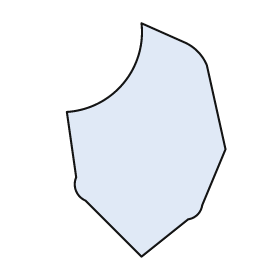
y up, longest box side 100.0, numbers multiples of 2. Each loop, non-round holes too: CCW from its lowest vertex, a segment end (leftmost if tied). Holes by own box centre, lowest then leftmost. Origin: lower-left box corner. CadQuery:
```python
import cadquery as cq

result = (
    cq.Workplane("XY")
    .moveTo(32.0, 0.0)
    .lineTo(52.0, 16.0)
    .threePointArc((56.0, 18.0), (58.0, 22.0))
    .lineTo(68.0, 46.0)
    .lineTo(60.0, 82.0)
    .threePointArc((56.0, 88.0), (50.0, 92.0))
    .lineTo(32.0, 100.0)
    .threePointArc((24.0, 74.0), (0.0, 62.0))
    .lineTo(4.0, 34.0)
    .threePointArc((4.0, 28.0), (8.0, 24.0))
    .close()
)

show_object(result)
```